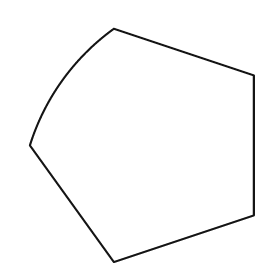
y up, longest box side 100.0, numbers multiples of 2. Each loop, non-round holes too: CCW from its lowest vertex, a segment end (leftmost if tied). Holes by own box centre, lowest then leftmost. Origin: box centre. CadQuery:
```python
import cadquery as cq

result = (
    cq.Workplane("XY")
    .moveTo(-12.0, -50.0)
    .lineTo(48.0, -30.0)
    .lineTo(48.0, 30.0)
    .lineTo(-12.0, 50.0)
    .threePointArc((-34.0, 28.0), (-48.0, 0.0))
    .close()
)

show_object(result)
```